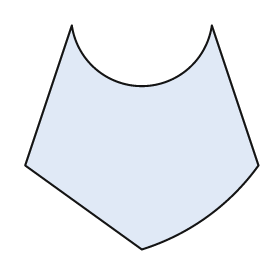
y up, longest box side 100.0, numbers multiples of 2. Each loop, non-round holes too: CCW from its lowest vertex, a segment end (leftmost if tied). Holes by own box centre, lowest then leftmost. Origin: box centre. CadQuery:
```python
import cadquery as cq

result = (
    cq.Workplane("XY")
    .moveTo(0.0, -48.0)
    .threePointArc((28.0, -34.0), (50.0, -12.0))
    .lineTo(30.0, 48.0)
    .threePointArc((0.0, 22.0), (-30.0, 48.0))
    .lineTo(-50.0, -12.0)
    .close()
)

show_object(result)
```